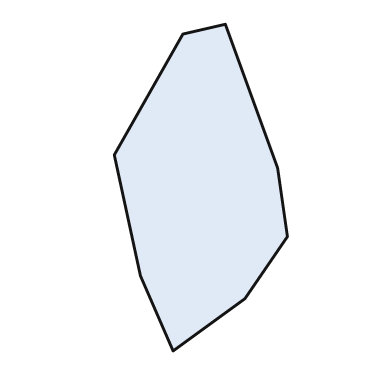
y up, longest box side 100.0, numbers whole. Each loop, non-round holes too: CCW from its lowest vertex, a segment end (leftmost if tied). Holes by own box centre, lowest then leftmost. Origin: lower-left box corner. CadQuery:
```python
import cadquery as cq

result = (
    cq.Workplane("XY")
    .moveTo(18.0, 0.0)
    .lineTo(40.0, 16.0)
    .lineTo(53.0, 35.0)
    .lineTo(50.0, 56.0)
    .lineTo(34.0, 100.0)
    .lineTo(21.0, 97.0)
    .lineTo(0.0, 60.0)
    .lineTo(8.0, 23.0)
    .close()
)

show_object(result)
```